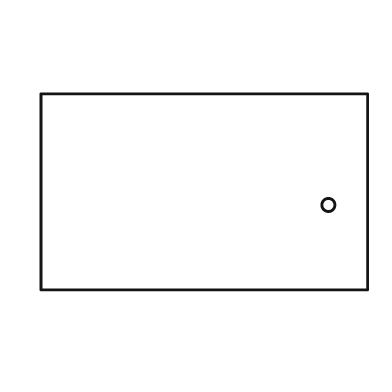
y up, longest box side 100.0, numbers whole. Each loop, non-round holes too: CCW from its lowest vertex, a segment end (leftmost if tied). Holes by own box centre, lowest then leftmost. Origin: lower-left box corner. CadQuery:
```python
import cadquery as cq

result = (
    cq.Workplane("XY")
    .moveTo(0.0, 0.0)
    .lineTo(100.0, 0.0)
    .lineTo(100.0, 60.0)
    .lineTo(0.0, 60.0)
    .close()
    .moveTo(88.0, 26.0)
    .circle(2.0)
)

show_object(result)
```